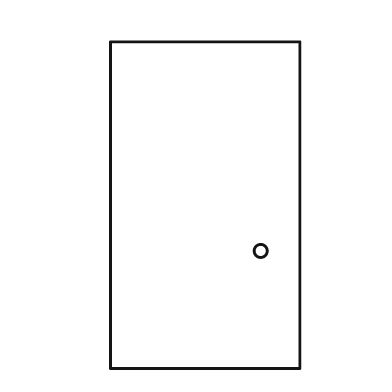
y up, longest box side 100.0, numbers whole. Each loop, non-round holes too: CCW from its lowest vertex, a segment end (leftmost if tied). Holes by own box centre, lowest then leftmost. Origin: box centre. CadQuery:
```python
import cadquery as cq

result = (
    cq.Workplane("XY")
    .moveTo(-29.0, -50.0)
    .lineTo(29.0, -50.0)
    .lineTo(29.0, 50.0)
    .lineTo(-29.0, 50.0)
    .close()
    .moveTo(17.0, -14.0)
    .circle(2.0)
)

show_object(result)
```